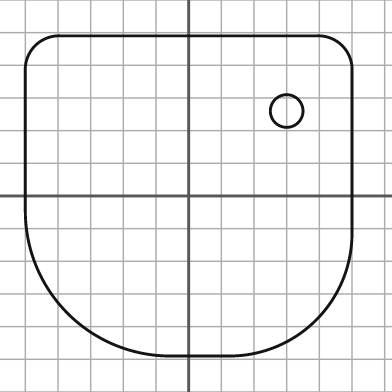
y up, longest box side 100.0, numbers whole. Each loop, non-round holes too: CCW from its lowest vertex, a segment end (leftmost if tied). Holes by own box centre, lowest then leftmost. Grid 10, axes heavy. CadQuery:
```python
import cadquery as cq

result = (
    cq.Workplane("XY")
    .moveTo(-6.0, -49.0)
    .lineTo(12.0, -49.0)
    .threePointArc((39.0, -38.0), (50.0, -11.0))
    .lineTo(50.0, 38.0)
    .threePointArc((47.0, 46.0), (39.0, 49.0))
    .lineTo(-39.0, 49.0)
    .threePointArc((-47.0, 46.0), (-50.0, 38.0))
    .lineTo(-50.0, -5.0)
    .threePointArc((-37.0, -36.0), (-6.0, -49.0))
    .close()
    .moveTo(30.0, 26.0)
    .circle(5.0)
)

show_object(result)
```